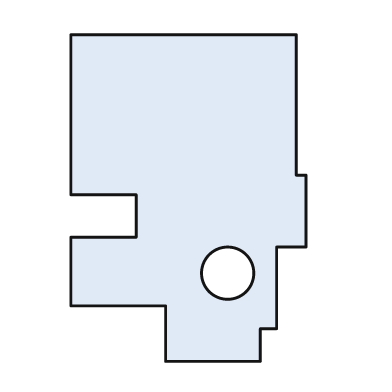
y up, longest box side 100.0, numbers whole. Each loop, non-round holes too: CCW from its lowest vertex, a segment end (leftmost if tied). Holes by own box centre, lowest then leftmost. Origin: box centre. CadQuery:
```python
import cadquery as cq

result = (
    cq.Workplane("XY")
    .moveTo(-7.0, -50.0)
    .lineTo(22.0, -50.0)
    .lineTo(22.0, -40.0)
    .lineTo(27.0, -40.0)
    .lineTo(27.0, -15.0)
    .lineTo(36.0, -15.0)
    .lineTo(36.0, 7.0)
    .lineTo(33.0, 7.0)
    .lineTo(33.0, 50.0)
    .lineTo(-36.0, 50.0)
    .lineTo(-36.0, 1.0)
    .lineTo(-16.0, 1.0)
    .lineTo(-16.0, -12.0)
    .lineTo(-36.0, -12.0)
    .lineTo(-36.0, -33.0)
    .lineTo(-7.0, -33.0)
    .close()
    .moveTo(12.0, -23.0)
    .circle(8.0)
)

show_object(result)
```